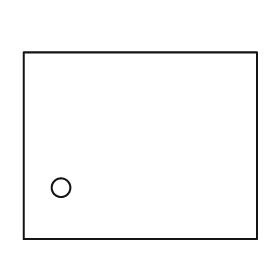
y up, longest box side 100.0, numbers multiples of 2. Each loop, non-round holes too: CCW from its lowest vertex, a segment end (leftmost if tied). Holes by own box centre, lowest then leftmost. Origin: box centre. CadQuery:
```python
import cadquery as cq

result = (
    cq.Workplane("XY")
    .moveTo(-50.0, -40.0)
    .lineTo(50.0, -40.0)
    .lineTo(50.0, 40.0)
    .lineTo(-50.0, 40.0)
    .close()
    .moveTo(-34.0, -18.0)
    .circle(4.0)
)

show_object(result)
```